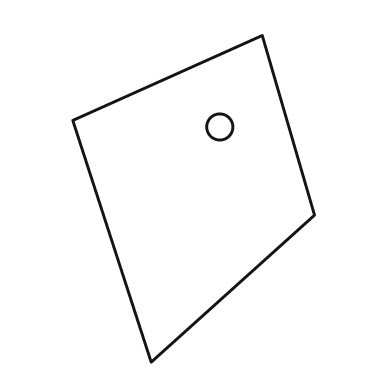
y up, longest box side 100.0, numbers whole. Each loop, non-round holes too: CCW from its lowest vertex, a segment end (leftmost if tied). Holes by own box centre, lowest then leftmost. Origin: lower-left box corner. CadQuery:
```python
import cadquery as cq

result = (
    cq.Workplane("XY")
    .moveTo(24.0, 0.0)
    .lineTo(74.0, 45.0)
    .lineTo(58.0, 100.0)
    .lineTo(0.0, 74.0)
    .close()
    .moveTo(45.0, 72.0)
    .circle(4.0)
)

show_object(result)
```